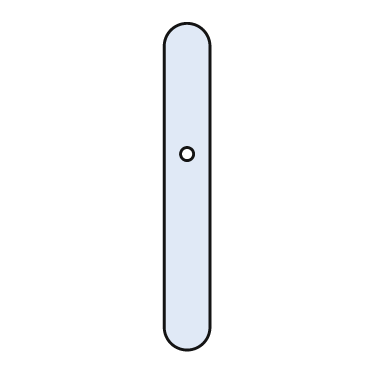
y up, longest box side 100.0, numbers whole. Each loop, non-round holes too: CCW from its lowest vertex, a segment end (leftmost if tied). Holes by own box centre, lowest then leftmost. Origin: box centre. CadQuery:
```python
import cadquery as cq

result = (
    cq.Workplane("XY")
    .moveTo(-7.0, -43.0)
    .threePointArc((0.0, -50.0), (7.0, -43.0))
    .lineTo(7.0, 43.0)
    .threePointArc((0.0, 50.0), (-7.0, 43.0))
    .close()
    .moveTo(0.0, 10.0)
    .circle(2.0)
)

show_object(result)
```